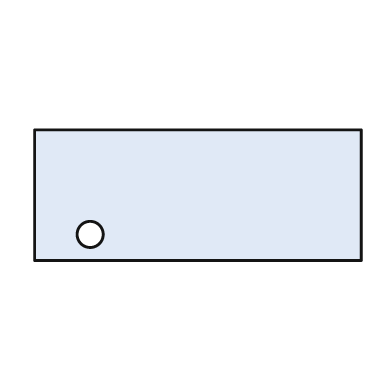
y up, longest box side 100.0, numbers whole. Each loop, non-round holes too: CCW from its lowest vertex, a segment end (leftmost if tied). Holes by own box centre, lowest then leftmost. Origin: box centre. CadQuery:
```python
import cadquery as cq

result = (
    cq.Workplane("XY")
    .moveTo(-50.0, -20.0)
    .lineTo(50.0, -20.0)
    .lineTo(50.0, 20.0)
    .lineTo(-50.0, 20.0)
    .close()
    .moveTo(-33.0, -12.0)
    .circle(4.0)
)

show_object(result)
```